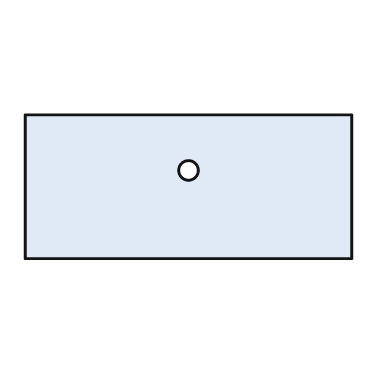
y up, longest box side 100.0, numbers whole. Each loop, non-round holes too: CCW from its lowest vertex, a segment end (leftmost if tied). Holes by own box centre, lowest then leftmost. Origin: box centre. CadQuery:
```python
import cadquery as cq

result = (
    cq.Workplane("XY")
    .moveTo(-50.0, -22.0)
    .lineTo(50.0, -22.0)
    .lineTo(50.0, 22.0)
    .lineTo(-50.0, 22.0)
    .close()
    .moveTo(0.0, 5.0)
    .circle(3.0)
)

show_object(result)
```